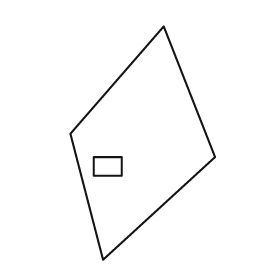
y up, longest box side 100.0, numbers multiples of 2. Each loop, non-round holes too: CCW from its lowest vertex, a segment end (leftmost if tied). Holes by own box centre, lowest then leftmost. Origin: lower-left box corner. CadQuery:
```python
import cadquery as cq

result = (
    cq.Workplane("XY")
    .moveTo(14.0, 0.0)
    .lineTo(62.0, 44.0)
    .lineTo(40.0, 100.0)
    .lineTo(0.0, 54.0)
    .close()
    .moveTo(10.0, 36.0)
    .lineTo(22.0, 36.0)
    .lineTo(22.0, 44.0)
    .lineTo(10.0, 44.0)
    .close()
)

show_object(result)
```